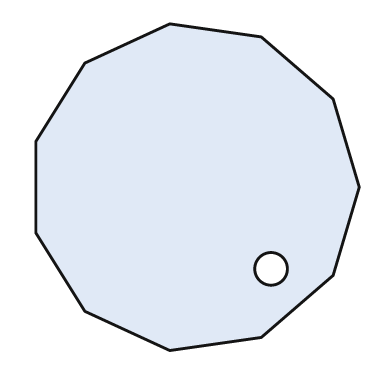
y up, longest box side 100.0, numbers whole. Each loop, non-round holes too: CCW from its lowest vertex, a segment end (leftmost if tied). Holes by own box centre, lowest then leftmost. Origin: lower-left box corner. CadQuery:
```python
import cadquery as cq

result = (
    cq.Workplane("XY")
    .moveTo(41.0, 0.0)
    .lineTo(69.0, 4.0)
    .lineTo(91.0, 23.0)
    .lineTo(99.0, 50.0)
    .lineTo(91.0, 77.0)
    .lineTo(69.0, 96.0)
    .lineTo(41.0, 100.0)
    .lineTo(15.0, 88.0)
    .lineTo(0.0, 64.0)
    .lineTo(0.0, 36.0)
    .lineTo(15.0, 12.0)
    .close()
    .moveTo(72.0, 25.0)
    .circle(5.0)
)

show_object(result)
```